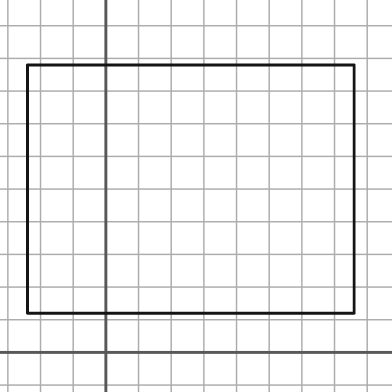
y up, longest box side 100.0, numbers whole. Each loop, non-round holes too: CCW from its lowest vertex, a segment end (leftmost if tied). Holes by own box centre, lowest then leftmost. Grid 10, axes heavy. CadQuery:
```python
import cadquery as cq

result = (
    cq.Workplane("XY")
    .moveTo(-24.0, 12.0)
    .lineTo(76.0, 12.0)
    .lineTo(76.0, 88.0)
    .lineTo(-24.0, 88.0)
    .close()
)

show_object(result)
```